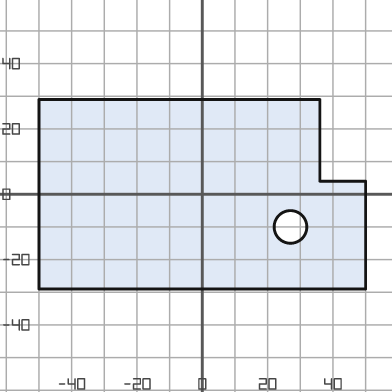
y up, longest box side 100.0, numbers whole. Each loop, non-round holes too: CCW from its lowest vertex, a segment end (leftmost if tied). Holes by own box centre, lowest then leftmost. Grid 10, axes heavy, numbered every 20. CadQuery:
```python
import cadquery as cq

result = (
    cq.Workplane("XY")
    .moveTo(-50.0, -29.0)
    .lineTo(50.0, -29.0)
    .lineTo(50.0, 4.0)
    .lineTo(36.0, 4.0)
    .lineTo(36.0, 29.0)
    .lineTo(-50.0, 29.0)
    .close()
    .moveTo(27.0, -10.0)
    .circle(5.0)
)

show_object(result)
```